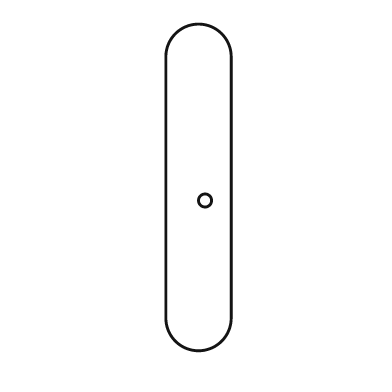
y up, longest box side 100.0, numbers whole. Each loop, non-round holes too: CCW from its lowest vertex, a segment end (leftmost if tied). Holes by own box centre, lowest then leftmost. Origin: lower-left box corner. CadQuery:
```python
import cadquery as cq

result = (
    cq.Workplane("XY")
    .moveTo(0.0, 10.0)
    .threePointArc((10.0, 0.0), (20.0, 10.0))
    .lineTo(20.0, 90.0)
    .threePointArc((10.0, 100.0), (0.0, 90.0))
    .close()
    .moveTo(12.0, 46.0)
    .circle(2.0)
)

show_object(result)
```